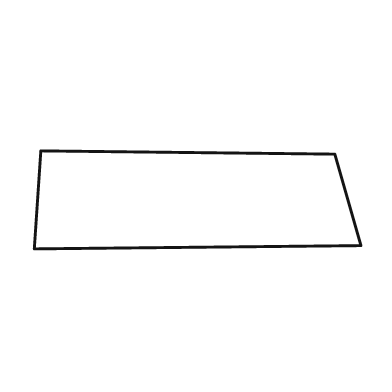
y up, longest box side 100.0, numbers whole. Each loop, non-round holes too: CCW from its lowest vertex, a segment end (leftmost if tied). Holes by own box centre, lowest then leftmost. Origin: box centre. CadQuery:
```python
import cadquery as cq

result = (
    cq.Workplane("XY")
    .moveTo(-50.0, -15.0)
    .lineTo(50.0, -14.0)
    .lineTo(42.0, 14.0)
    .lineTo(-48.0, 15.0)
    .close()
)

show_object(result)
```